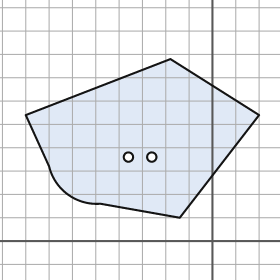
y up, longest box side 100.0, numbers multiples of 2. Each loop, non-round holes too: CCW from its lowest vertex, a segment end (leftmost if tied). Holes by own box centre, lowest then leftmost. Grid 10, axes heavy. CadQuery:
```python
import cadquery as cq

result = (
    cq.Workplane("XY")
    .moveTo(-14.0, 10.0)
    .lineTo(20.0, 54.0)
    .lineTo(-18.0, 78.0)
    .lineTo(-80.0, 54.0)
    .lineTo(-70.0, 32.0)
    .threePointArc((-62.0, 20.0), (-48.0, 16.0))
    .close()
    .moveTo(-36.0, 36.0)
    .circle(2.0)
    .moveTo(-26.0, 36.0)
    .circle(2.0)
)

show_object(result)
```